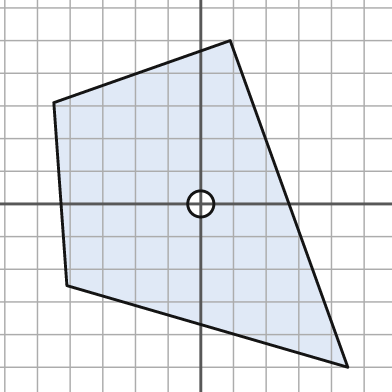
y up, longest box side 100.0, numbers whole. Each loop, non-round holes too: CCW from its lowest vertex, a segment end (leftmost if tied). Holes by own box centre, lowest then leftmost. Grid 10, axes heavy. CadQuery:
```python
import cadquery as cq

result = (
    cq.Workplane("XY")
    .moveTo(45.0, -50.0)
    .lineTo(9.0, 50.0)
    .lineTo(-45.0, 31.0)
    .lineTo(-41.0, -25.0)
    .close()
    .moveTo(0.0, 0.0)
    .circle(4.0)
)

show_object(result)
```